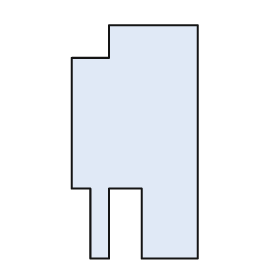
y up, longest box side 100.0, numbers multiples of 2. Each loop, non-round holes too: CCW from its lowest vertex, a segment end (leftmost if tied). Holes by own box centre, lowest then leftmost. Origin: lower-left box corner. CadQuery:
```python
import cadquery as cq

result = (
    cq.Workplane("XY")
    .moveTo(8.0, 0.0)
    .lineTo(16.0, 0.0)
    .lineTo(16.0, 30.0)
    .lineTo(30.0, 30.0)
    .lineTo(30.0, 0.0)
    .lineTo(54.0, 0.0)
    .lineTo(54.0, 100.0)
    .lineTo(16.0, 100.0)
    .lineTo(16.0, 86.0)
    .lineTo(0.0, 86.0)
    .lineTo(0.0, 30.0)
    .lineTo(8.0, 30.0)
    .close()
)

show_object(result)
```